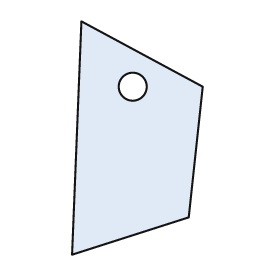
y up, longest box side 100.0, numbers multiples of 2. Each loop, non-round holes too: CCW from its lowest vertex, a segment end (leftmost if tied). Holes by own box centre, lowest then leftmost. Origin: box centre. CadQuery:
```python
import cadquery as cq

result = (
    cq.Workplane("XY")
    .moveTo(-28.0, -50.0)
    .lineTo(22.0, -34.0)
    .lineTo(28.0, 22.0)
    .lineTo(-24.0, 50.0)
    .close()
    .moveTo(-2.0, 22.0)
    .circle(6.0)
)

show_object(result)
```